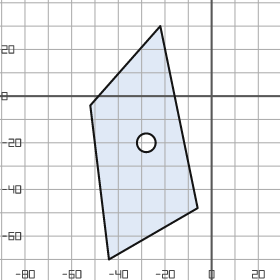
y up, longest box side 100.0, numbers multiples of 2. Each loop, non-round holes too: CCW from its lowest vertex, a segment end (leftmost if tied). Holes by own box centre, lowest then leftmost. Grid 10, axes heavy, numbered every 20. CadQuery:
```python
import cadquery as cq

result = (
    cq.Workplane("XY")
    .moveTo(-44.0, -70.0)
    .lineTo(-6.0, -48.0)
    .lineTo(-22.0, 30.0)
    .lineTo(-52.0, -4.0)
    .close()
    .moveTo(-28.0, -20.0)
    .circle(4.0)
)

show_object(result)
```